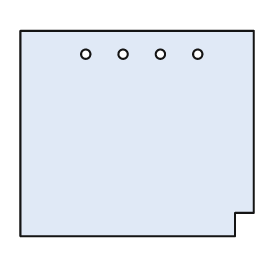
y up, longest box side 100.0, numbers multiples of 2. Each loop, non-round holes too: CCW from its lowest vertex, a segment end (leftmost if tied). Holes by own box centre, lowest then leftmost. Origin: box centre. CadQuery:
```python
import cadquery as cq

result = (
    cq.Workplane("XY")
    .moveTo(-50.0, -44.0)
    .lineTo(42.0, -44.0)
    .lineTo(42.0, -34.0)
    .lineTo(50.0, -34.0)
    .lineTo(50.0, 44.0)
    .lineTo(-50.0, 44.0)
    .close()
    .moveTo(-22.0, 34.0)
    .circle(2.0)
    .moveTo(-6.0, 34.0)
    .circle(2.0)
    .moveTo(10.0, 34.0)
    .circle(2.0)
    .moveTo(26.0, 34.0)
    .circle(2.0)
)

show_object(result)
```